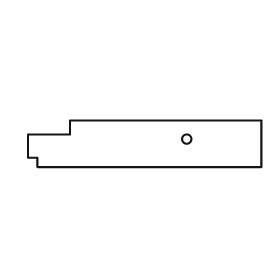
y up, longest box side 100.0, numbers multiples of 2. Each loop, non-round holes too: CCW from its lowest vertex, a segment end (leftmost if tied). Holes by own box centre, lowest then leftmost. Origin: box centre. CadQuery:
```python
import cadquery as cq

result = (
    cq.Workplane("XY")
    .moveTo(-46.0, -10.0)
    .lineTo(50.0, -10.0)
    .lineTo(50.0, 10.0)
    .lineTo(-32.0, 10.0)
    .lineTo(-32.0, 4.0)
    .lineTo(-50.0, 4.0)
    .lineTo(-50.0, -6.0)
    .lineTo(-46.0, -6.0)
    .close()
    .moveTo(18.0, 2.0)
    .circle(2.0)
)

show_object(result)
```